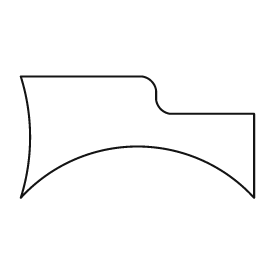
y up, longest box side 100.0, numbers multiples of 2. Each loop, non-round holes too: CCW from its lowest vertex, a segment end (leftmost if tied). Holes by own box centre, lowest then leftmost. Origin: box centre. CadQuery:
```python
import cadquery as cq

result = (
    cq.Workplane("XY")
    .moveTo(-50.0, -26.0)
    .threePointArc((0.0, -4.0), (50.0, -26.0))
    .lineTo(50.0, 10.0)
    .lineTo(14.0, 10.0)
    .threePointArc((10.0, 12.0), (8.0, 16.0))
    .lineTo(8.0, 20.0)
    .threePointArc((6.0, 24.0), (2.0, 26.0))
    .lineTo(-50.0, 26.0)
    .threePointArc((-46.0, 0.0), (-50.0, -26.0))
    .close()
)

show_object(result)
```